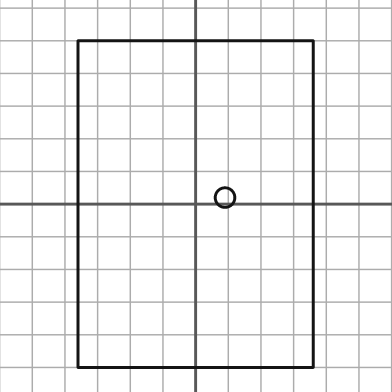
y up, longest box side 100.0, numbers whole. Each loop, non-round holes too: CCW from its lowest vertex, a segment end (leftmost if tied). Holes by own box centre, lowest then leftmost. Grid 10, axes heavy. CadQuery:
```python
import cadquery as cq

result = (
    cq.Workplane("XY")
    .moveTo(-36.0, -50.0)
    .lineTo(36.0, -50.0)
    .lineTo(36.0, 50.0)
    .lineTo(-36.0, 50.0)
    .close()
    .moveTo(9.0, 2.0)
    .circle(3.0)
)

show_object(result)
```